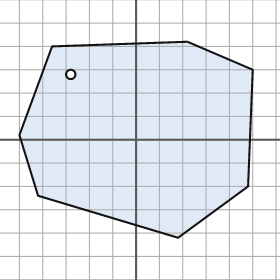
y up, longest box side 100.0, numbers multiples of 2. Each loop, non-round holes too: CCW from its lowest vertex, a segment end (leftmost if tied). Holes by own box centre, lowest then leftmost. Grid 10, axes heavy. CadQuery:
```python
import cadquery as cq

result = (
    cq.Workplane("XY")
    .moveTo(18.0, -42.0)
    .lineTo(48.0, -20.0)
    .lineTo(50.0, 30.0)
    .lineTo(22.0, 42.0)
    .lineTo(-36.0, 40.0)
    .lineTo(-50.0, 2.0)
    .lineTo(-42.0, -24.0)
    .close()
    .moveTo(-28.0, 28.0)
    .circle(2.0)
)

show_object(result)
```